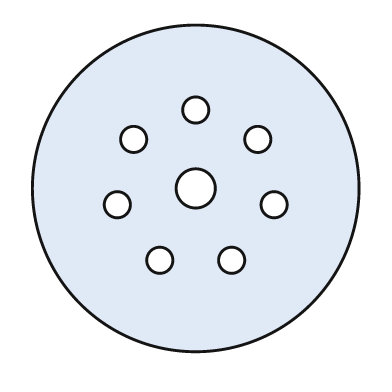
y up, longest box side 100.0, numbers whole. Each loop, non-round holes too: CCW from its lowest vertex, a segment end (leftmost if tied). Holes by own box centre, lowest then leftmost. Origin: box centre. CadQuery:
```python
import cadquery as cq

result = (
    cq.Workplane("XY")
    .moveTo(0.0, 0.0)
    .circle(50.0)
    .moveTo(-11.0, -22.0)
    .circle(4.0)
    .moveTo(11.0, -22.0)
    .circle(4.0)
    .moveTo(-24.0, -5.0)
    .circle(4.0)
    .moveTo(24.0, -5.0)
    .circle(4.0)
    .moveTo(0.0, 0.0)
    .circle(6.0)
    .moveTo(-19.0, 15.0)
    .circle(4.0)
    .moveTo(19.0, 15.0)
    .circle(4.0)
    .moveTo(0.0, 24.0)
    .circle(4.0)
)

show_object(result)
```